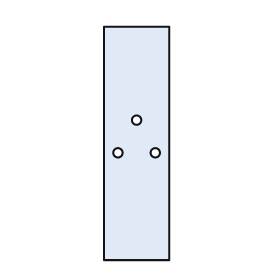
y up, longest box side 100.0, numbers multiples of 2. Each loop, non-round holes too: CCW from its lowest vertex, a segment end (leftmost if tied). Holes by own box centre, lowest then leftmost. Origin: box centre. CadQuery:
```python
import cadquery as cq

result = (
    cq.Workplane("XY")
    .moveTo(-14.0, -50.0)
    .lineTo(14.0, -50.0)
    .lineTo(14.0, 50.0)
    .lineTo(-14.0, 50.0)
    .close()
    .moveTo(-8.0, -4.0)
    .circle(2.0)
    .moveTo(8.0, -4.0)
    .circle(2.0)
    .moveTo(0.0, 10.0)
    .circle(2.0)
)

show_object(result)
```